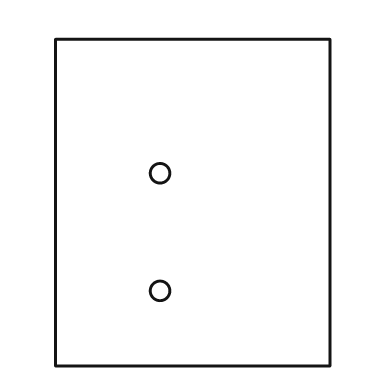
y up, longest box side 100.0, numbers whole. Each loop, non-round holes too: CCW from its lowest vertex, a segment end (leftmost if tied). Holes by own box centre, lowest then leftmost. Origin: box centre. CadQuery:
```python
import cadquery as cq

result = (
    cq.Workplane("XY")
    .moveTo(-42.0, -50.0)
    .lineTo(42.0, -50.0)
    .lineTo(42.0, 50.0)
    .lineTo(-42.0, 50.0)
    .close()
    .moveTo(-10.0, -27.0)
    .circle(3.0)
    .moveTo(-10.0, 9.0)
    .circle(3.0)
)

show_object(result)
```